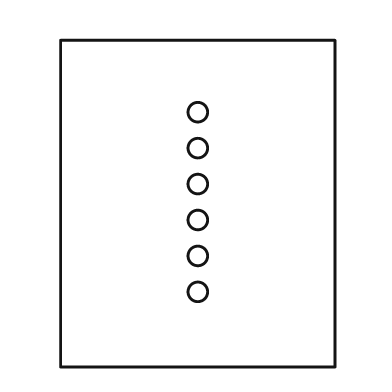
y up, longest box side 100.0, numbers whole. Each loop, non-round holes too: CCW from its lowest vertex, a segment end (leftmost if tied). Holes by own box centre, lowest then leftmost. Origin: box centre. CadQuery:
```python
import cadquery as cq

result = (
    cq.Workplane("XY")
    .moveTo(-42.0, -50.0)
    .lineTo(42.0, -50.0)
    .lineTo(42.0, 50.0)
    .lineTo(-42.0, 50.0)
    .close()
    .moveTo(0.0, -27.0)
    .circle(3.0)
    .moveTo(0.0, -16.0)
    .circle(3.0)
    .moveTo(0.0, -5.0)
    .circle(3.0)
    .moveTo(0.0, 6.0)
    .circle(3.0)
    .moveTo(0.0, 17.0)
    .circle(3.0)
    .moveTo(0.0, 28.0)
    .circle(3.0)
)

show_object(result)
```